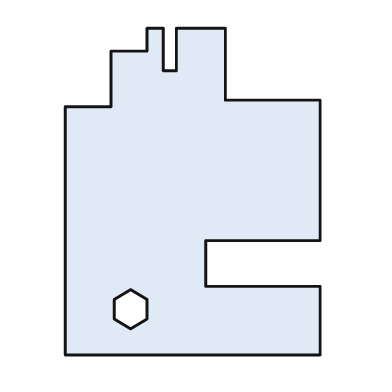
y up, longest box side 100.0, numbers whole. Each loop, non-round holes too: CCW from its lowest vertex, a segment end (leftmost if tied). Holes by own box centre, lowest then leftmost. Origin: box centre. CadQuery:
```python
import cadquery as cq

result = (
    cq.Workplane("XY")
    .moveTo(-39.0, -50.0)
    .lineTo(39.0, -50.0)
    .lineTo(39.0, -29.0)
    .lineTo(4.0, -29.0)
    .lineTo(4.0, -15.0)
    .lineTo(39.0, -15.0)
    .lineTo(39.0, 28.0)
    .lineTo(10.0, 28.0)
    .lineTo(10.0, 50.0)
    .lineTo(-5.0, 50.0)
    .lineTo(-5.0, 37.0)
    .lineTo(-9.0, 37.0)
    .lineTo(-9.0, 50.0)
    .lineTo(-14.0, 50.0)
    .lineTo(-14.0, 43.0)
    .lineTo(-25.0, 43.0)
    .lineTo(-25.0, 26.0)
    .lineTo(-39.0, 26.0)
    .close()
    .moveTo(-19.0, -42.0)
    .lineTo(-14.0, -39.0)
    .lineTo(-14.0, -33.0)
    .lineTo(-19.0, -30.0)
    .lineTo(-24.0, -33.0)
    .lineTo(-24.0, -39.0)
    .close()
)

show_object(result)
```